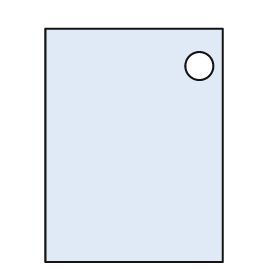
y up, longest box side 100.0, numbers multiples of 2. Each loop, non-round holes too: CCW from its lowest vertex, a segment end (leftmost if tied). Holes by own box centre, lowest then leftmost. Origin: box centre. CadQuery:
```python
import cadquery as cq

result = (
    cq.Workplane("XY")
    .moveTo(-38.0, -50.0)
    .lineTo(38.0, -50.0)
    .lineTo(38.0, 50.0)
    .lineTo(-38.0, 50.0)
    .close()
    .moveTo(28.0, 34.0)
    .circle(6.0)
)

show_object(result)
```